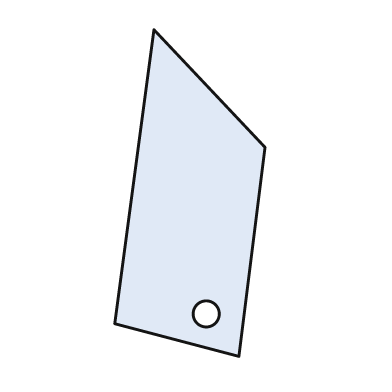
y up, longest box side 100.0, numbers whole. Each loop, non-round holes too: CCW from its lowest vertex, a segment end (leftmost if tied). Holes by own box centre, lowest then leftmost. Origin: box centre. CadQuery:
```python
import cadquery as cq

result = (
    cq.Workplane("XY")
    .moveTo(15.0, -50.0)
    .lineTo(23.0, 14.0)
    .lineTo(-11.0, 50.0)
    .lineTo(-23.0, -40.0)
    .close()
    .moveTo(5.0, -37.0)
    .circle(4.0)
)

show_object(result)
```